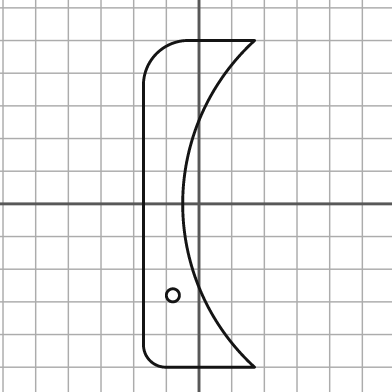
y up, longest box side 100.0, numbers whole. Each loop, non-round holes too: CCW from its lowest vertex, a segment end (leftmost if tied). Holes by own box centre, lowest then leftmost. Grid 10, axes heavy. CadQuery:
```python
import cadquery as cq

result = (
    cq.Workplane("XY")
    .moveTo(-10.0, -50.0)
    .lineTo(17.0, -50.0)
    .threePointArc((-5.0, 0.0), (17.0, 50.0))
    .lineTo(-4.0, 50.0)
    .threePointArc((-13.0, 46.0), (-17.0, 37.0))
    .lineTo(-17.0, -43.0)
    .threePointArc((-15.0, -48.0), (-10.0, -50.0))
    .close()
    .moveTo(-8.0, -28.0)
    .circle(2.0)
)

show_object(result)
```